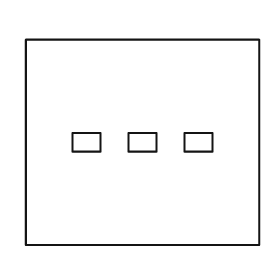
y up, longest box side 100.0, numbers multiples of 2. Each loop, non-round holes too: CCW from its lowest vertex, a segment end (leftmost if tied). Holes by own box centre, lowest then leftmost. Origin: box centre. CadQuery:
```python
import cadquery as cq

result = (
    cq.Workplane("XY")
    .moveTo(-50.0, -44.0)
    .lineTo(50.0, -44.0)
    .lineTo(50.0, 44.0)
    .lineTo(-50.0, 44.0)
    .close()
    .moveTo(-30.0, -4.0)
    .lineTo(-18.0, -4.0)
    .lineTo(-18.0, 4.0)
    .lineTo(-30.0, 4.0)
    .close()
    .moveTo(-6.0, -4.0)
    .lineTo(6.0, -4.0)
    .lineTo(6.0, 4.0)
    .lineTo(-6.0, 4.0)
    .close()
    .moveTo(18.0, -4.0)
    .lineTo(30.0, -4.0)
    .lineTo(30.0, 4.0)
    .lineTo(18.0, 4.0)
    .close()
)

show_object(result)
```